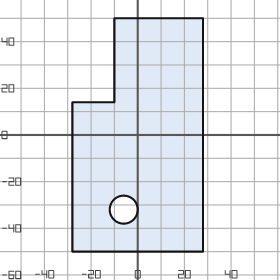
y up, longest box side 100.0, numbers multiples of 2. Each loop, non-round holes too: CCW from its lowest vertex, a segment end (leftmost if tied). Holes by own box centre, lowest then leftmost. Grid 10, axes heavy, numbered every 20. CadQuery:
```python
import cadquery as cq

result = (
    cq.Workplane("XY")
    .moveTo(-28.0, -50.0)
    .lineTo(28.0, -50.0)
    .lineTo(28.0, 50.0)
    .lineTo(-10.0, 50.0)
    .lineTo(-10.0, 14.0)
    .lineTo(-28.0, 14.0)
    .close()
    .moveTo(-6.0, -32.0)
    .circle(6.0)
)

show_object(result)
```